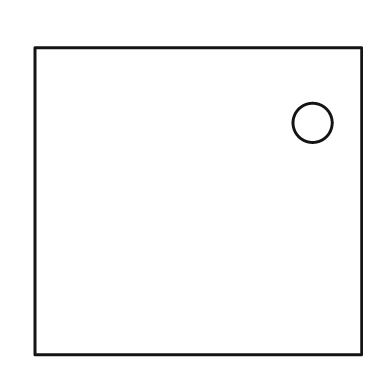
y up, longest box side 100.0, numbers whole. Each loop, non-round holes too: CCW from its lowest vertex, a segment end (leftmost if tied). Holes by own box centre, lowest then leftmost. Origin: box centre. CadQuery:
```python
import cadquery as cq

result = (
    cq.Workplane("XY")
    .moveTo(-50.0, -47.0)
    .lineTo(50.0, -47.0)
    .lineTo(50.0, 47.0)
    .lineTo(-50.0, 47.0)
    .close()
    .moveTo(35.0, 24.0)
    .circle(6.0)
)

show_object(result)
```